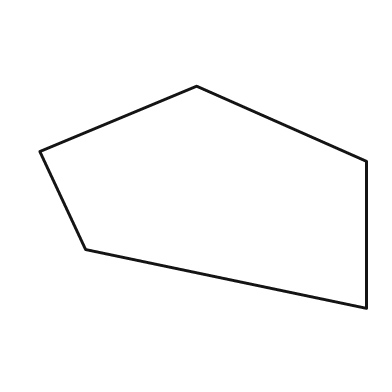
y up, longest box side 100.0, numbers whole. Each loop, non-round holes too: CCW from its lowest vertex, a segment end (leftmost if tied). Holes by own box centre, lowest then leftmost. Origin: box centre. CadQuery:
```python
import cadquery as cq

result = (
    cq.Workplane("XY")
    .moveTo(50.0, -34.0)
    .lineTo(50.0, 11.0)
    .lineTo(-2.0, 34.0)
    .lineTo(-50.0, 14.0)
    .lineTo(-36.0, -16.0)
    .close()
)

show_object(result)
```